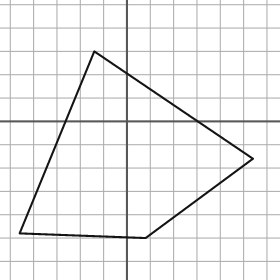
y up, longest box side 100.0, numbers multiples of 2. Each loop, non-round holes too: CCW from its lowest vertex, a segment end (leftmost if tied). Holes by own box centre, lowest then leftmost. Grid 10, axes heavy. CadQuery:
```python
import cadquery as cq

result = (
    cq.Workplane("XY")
    .moveTo(8.0, -50.0)
    .lineTo(54.0, -16.0)
    .lineTo(-14.0, 30.0)
    .lineTo(-46.0, -48.0)
    .close()
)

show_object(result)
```